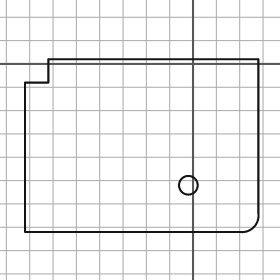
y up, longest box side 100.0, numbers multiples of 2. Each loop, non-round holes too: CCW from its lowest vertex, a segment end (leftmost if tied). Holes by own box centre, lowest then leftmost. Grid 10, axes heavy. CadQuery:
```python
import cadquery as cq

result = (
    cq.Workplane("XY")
    .moveTo(-72.0, -72.0)
    .lineTo(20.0, -72.0)
    .threePointArc((26.0, -70.0), (28.0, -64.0))
    .lineTo(28.0, 2.0)
    .lineTo(-62.0, 2.0)
    .lineTo(-62.0, -8.0)
    .lineTo(-72.0, -8.0)
    .close()
    .moveTo(-2.0, -52.0)
    .circle(4.0)
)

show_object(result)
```